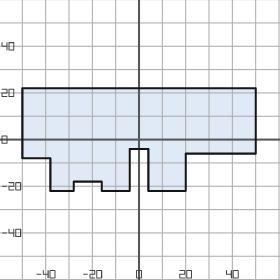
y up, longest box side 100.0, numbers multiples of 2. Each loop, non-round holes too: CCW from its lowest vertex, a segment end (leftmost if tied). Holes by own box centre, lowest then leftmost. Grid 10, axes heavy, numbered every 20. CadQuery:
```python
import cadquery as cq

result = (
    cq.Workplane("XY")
    .moveTo(-38.0, -22.0)
    .lineTo(-28.0, -22.0)
    .lineTo(-28.0, -18.0)
    .lineTo(-16.0, -18.0)
    .lineTo(-16.0, -22.0)
    .lineTo(-4.0, -22.0)
    .lineTo(-4.0, -4.0)
    .lineTo(4.0, -4.0)
    .lineTo(4.0, -22.0)
    .lineTo(20.0, -22.0)
    .lineTo(20.0, -6.0)
    .lineTo(50.0, -6.0)
    .lineTo(50.0, 22.0)
    .lineTo(-50.0, 22.0)
    .lineTo(-50.0, -8.0)
    .lineTo(-38.0, -8.0)
    .close()
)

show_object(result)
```